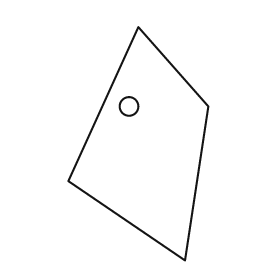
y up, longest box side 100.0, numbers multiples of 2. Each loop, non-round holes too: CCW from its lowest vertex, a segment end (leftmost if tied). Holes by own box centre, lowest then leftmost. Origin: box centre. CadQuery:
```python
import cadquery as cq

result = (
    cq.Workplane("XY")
    .moveTo(20.0, -50.0)
    .lineTo(30.0, 16.0)
    .lineTo(0.0, 50.0)
    .lineTo(-30.0, -16.0)
    .close()
    .moveTo(-4.0, 16.0)
    .circle(4.0)
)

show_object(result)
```